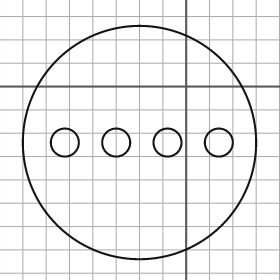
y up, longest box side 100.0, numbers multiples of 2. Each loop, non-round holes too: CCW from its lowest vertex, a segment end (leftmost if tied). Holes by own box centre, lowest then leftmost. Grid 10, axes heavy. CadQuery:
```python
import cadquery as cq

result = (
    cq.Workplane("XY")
    .moveTo(-20.0, -24.0)
    .circle(50.0)
    .moveTo(-52.0, -24.0)
    .circle(6.0)
    .moveTo(-30.0, -24.0)
    .circle(6.0)
    .moveTo(-8.0, -24.0)
    .circle(6.0)
    .moveTo(14.0, -24.0)
    .circle(6.0)
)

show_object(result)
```